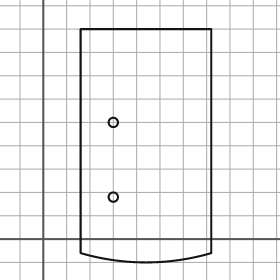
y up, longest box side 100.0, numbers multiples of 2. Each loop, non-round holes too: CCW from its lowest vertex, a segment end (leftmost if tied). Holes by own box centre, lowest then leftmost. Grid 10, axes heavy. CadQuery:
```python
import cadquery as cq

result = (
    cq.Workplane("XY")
    .moveTo(16.0, -6.0)
    .threePointArc((44.0, -10.0), (72.0, -6.0))
    .lineTo(72.0, 90.0)
    .lineTo(16.0, 90.0)
    .close()
    .moveTo(30.0, 18.0)
    .circle(2.0)
    .moveTo(30.0, 50.0)
    .circle(2.0)
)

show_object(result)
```